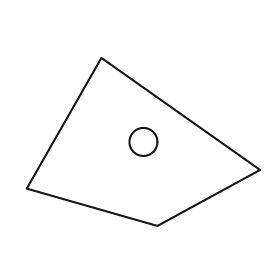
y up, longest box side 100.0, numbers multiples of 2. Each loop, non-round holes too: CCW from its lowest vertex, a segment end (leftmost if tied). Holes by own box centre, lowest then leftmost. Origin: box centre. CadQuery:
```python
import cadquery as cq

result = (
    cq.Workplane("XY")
    .moveTo(6.0, -36.0)
    .lineTo(50.0, -12.0)
    .lineTo(-18.0, 36.0)
    .lineTo(-50.0, -20.0)
    .close()
    .moveTo(0.0, 0.0)
    .circle(6.0)
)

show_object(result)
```